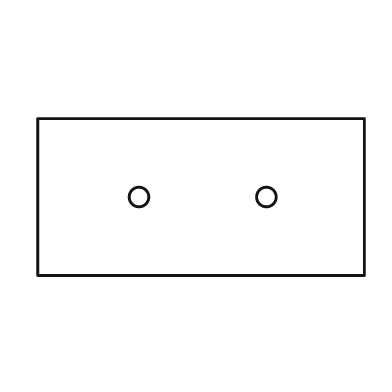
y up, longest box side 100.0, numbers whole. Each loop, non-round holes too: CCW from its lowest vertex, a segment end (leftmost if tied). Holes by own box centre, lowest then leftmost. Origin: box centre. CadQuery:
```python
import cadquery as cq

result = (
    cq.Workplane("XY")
    .moveTo(-50.0, -24.0)
    .lineTo(50.0, -24.0)
    .lineTo(50.0, 24.0)
    .lineTo(-50.0, 24.0)
    .close()
    .moveTo(-19.0, 0.0)
    .circle(3.0)
    .moveTo(20.0, 0.0)
    .circle(3.0)
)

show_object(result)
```